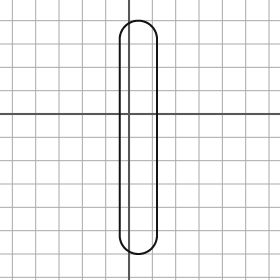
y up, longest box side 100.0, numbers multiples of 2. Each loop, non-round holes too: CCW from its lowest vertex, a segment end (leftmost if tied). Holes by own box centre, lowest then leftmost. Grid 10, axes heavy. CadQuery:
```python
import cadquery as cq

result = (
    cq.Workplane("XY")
    .moveTo(-4.0, -52.0)
    .threePointArc((4.0, -60.0), (12.0, -52.0))
    .lineTo(12.0, 32.0)
    .threePointArc((4.0, 40.0), (-4.0, 32.0))
    .close()
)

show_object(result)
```